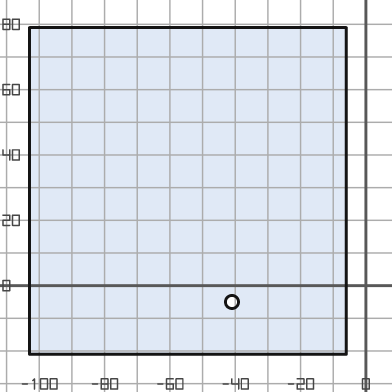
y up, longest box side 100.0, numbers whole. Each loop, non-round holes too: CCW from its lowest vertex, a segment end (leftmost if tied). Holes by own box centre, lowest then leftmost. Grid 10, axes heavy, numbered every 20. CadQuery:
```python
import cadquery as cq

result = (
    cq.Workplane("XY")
    .moveTo(-103.0, -21.0)
    .lineTo(-6.0, -21.0)
    .lineTo(-6.0, 79.0)
    .lineTo(-103.0, 79.0)
    .close()
    .moveTo(-41.0, -5.0)
    .circle(2.0)
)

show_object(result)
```